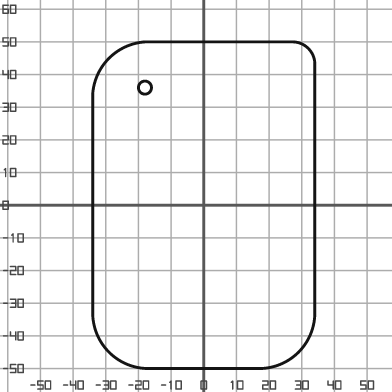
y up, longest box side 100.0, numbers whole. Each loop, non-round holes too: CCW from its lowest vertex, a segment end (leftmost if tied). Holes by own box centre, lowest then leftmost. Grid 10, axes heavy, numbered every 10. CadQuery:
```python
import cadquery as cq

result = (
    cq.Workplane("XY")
    .moveTo(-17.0, -50.0)
    .lineTo(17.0, -50.0)
    .threePointArc((29.0, -45.0), (34.0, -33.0))
    .lineTo(34.0, 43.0)
    .threePointArc((32.0, 48.0), (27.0, 50.0))
    .lineTo(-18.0, 50.0)
    .threePointArc((-29.0, 45.0), (-34.0, 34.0))
    .lineTo(-34.0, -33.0)
    .threePointArc((-29.0, -45.0), (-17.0, -50.0))
    .close()
    .moveTo(-18.0, 36.0)
    .circle(2.0)
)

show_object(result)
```